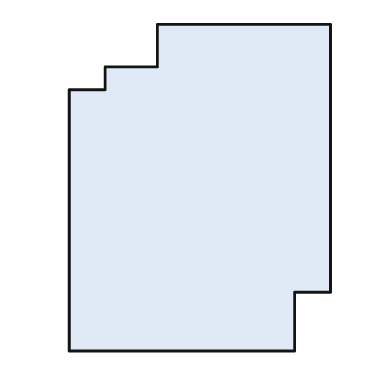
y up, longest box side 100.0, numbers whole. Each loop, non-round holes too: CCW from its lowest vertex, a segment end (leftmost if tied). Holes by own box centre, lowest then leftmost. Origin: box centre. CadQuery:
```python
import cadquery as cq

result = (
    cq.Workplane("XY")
    .moveTo(-40.0, -50.0)
    .lineTo(29.0, -50.0)
    .lineTo(29.0, -32.0)
    .lineTo(40.0, -32.0)
    .lineTo(40.0, 50.0)
    .lineTo(-13.0, 50.0)
    .lineTo(-13.0, 37.0)
    .lineTo(-29.0, 37.0)
    .lineTo(-29.0, 30.0)
    .lineTo(-40.0, 30.0)
    .close()
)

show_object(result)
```